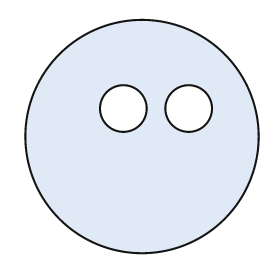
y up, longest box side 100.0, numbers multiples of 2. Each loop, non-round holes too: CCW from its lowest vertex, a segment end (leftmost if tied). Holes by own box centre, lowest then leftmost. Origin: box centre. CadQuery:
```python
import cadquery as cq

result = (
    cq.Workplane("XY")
    .moveTo(0.0, 0.0)
    .circle(50.0)
    .moveTo(-8.0, 12.0)
    .circle(10.0)
    .moveTo(20.0, 12.0)
    .circle(10.0)
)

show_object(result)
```